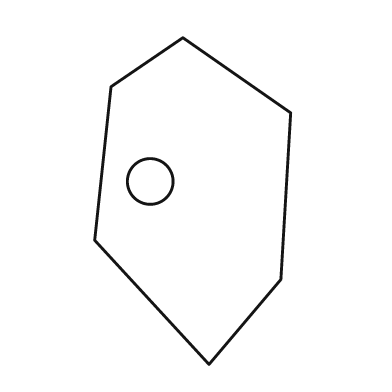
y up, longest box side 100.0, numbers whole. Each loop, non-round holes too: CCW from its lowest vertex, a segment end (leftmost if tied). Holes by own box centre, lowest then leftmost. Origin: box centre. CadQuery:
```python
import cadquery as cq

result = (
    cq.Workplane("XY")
    .moveTo(5.0, -50.0)
    .lineTo(27.0, -24.0)
    .lineTo(30.0, 27.0)
    .lineTo(-3.0, 50.0)
    .lineTo(-25.0, 35.0)
    .lineTo(-30.0, -12.0)
    .close()
    .moveTo(-13.0, 6.0)
    .circle(7.0)
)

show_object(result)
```